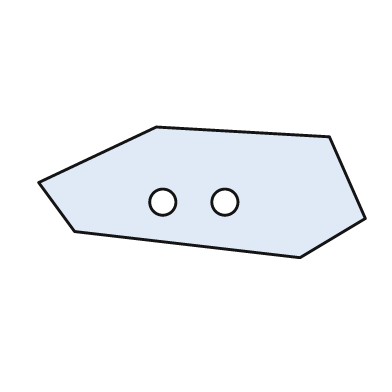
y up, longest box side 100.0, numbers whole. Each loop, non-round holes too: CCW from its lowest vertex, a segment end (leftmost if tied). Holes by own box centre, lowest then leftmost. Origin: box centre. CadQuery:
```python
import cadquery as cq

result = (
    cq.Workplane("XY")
    .moveTo(30.0, -20.0)
    .lineTo(50.0, -8.0)
    .lineTo(39.0, 17.0)
    .lineTo(-14.0, 20.0)
    .lineTo(-50.0, 3.0)
    .lineTo(-39.0, -12.0)
    .close()
    .moveTo(-12.0, -3.0)
    .circle(4.0)
    .moveTo(7.0, -3.0)
    .circle(4.0)
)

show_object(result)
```